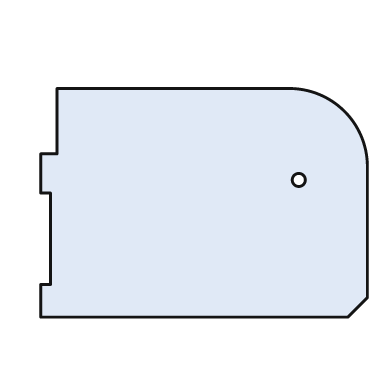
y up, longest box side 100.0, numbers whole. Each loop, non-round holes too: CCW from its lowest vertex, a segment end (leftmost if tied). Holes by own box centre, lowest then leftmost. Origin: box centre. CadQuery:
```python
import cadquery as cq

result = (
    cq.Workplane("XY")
    .moveTo(-50.0, -35.0)
    .lineTo(44.0, -35.0)
    .lineTo(50.0, -29.0)
    .lineTo(50.0, 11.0)
    .threePointArc((43.0, 28.0), (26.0, 35.0))
    .lineTo(-45.0, 35.0)
    .lineTo(-45.0, 15.0)
    .lineTo(-50.0, 15.0)
    .lineTo(-50.0, 3.0)
    .lineTo(-47.0, 3.0)
    .lineTo(-47.0, -25.0)
    .lineTo(-50.0, -25.0)
    .close()
    .moveTo(29.0, 7.0)
    .circle(2.0)
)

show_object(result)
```